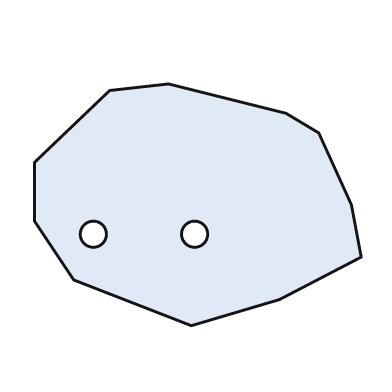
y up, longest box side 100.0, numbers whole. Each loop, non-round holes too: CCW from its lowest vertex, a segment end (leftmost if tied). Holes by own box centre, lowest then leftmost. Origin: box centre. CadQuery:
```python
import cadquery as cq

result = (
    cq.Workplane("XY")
    .moveTo(-2.0, -37.0)
    .lineTo(25.0, -29.0)
    .lineTo(50.0, -16.0)
    .lineTo(47.0, 0.0)
    .lineTo(37.0, 22.0)
    .lineTo(27.0, 28.0)
    .lineTo(-9.0, 37.0)
    .lineTo(-27.0, 35.0)
    .lineTo(-50.0, 13.0)
    .lineTo(-50.0, -5.0)
    .lineTo(-38.0, -23.0)
    .close()
    .moveTo(-32.0, -9.0)
    .circle(4.0)
    .moveTo(-1.0, -9.0)
    .circle(4.0)
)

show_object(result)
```